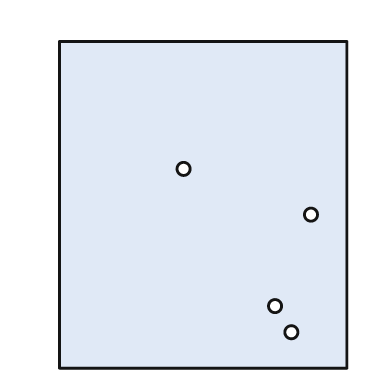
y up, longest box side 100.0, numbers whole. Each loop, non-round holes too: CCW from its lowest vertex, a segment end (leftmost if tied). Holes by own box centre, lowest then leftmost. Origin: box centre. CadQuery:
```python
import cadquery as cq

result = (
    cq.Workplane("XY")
    .moveTo(-44.0, -50.0)
    .lineTo(44.0, -50.0)
    .lineTo(44.0, 50.0)
    .lineTo(-44.0, 50.0)
    .close()
    .moveTo(27.0, -39.0)
    .circle(2.0)
    .moveTo(22.0, -31.0)
    .circle(2.0)
    .moveTo(33.0, -3.0)
    .circle(2.0)
    .moveTo(-6.0, 11.0)
    .circle(2.0)
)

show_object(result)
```